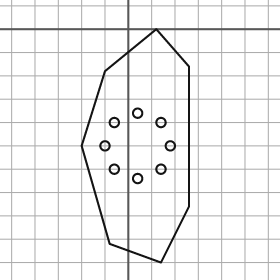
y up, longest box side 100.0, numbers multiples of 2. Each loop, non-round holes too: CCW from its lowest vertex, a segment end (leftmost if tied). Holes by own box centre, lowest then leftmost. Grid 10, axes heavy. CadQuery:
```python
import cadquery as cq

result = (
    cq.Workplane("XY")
    .moveTo(14.0, -100.0)
    .lineTo(26.0, -76.0)
    .lineTo(26.0, -16.0)
    .lineTo(12.0, 0.0)
    .lineTo(-10.0, -18.0)
    .lineTo(-20.0, -50.0)
    .lineTo(-8.0, -92.0)
    .close()
    .moveTo(4.0, -64.0)
    .circle(2.0)
    .moveTo(-6.0, -60.0)
    .circle(2.0)
    .moveTo(14.0, -60.0)
    .circle(2.0)
    .moveTo(-10.0, -50.0)
    .circle(2.0)
    .moveTo(18.0, -50.0)
    .circle(2.0)
    .moveTo(-6.0, -40.0)
    .circle(2.0)
    .moveTo(14.0, -40.0)
    .circle(2.0)
    .moveTo(4.0, -36.0)
    .circle(2.0)
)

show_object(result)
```